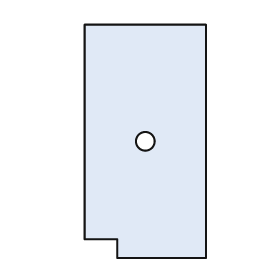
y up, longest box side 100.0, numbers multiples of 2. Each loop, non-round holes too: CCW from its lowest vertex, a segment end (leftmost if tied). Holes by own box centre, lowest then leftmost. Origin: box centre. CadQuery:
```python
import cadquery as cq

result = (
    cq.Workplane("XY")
    .moveTo(-12.0, -50.0)
    .lineTo(26.0, -50.0)
    .lineTo(26.0, 50.0)
    .lineTo(-26.0, 50.0)
    .lineTo(-26.0, -42.0)
    .lineTo(-12.0, -42.0)
    .close()
    .moveTo(0.0, 0.0)
    .circle(4.0)
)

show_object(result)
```